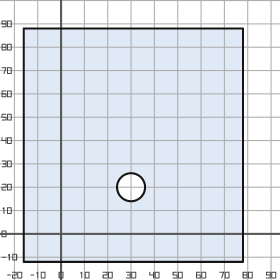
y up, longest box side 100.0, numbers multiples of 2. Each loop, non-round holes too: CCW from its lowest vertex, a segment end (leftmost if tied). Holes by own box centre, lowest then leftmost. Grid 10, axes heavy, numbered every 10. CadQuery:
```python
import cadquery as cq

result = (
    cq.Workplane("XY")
    .moveTo(-16.0, -12.0)
    .lineTo(78.0, -12.0)
    .lineTo(78.0, 88.0)
    .lineTo(-16.0, 88.0)
    .close()
    .moveTo(30.0, 20.0)
    .circle(6.0)
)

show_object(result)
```